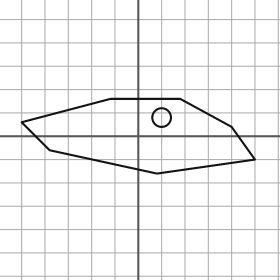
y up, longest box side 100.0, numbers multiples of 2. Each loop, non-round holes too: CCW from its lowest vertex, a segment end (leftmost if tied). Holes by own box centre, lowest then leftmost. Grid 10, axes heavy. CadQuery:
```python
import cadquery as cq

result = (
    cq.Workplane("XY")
    .moveTo(8.0, -16.0)
    .lineTo(50.0, -10.0)
    .lineTo(40.0, 4.0)
    .lineTo(18.0, 16.0)
    .lineTo(-12.0, 16.0)
    .lineTo(-50.0, 6.0)
    .lineTo(-38.0, -6.0)
    .close()
    .moveTo(10.0, 8.0)
    .circle(4.0)
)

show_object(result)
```